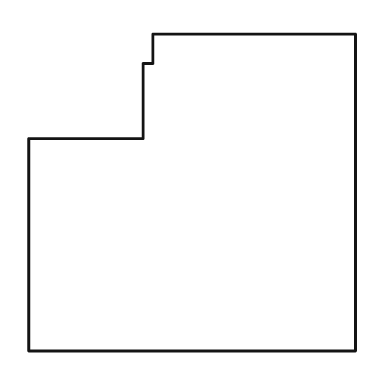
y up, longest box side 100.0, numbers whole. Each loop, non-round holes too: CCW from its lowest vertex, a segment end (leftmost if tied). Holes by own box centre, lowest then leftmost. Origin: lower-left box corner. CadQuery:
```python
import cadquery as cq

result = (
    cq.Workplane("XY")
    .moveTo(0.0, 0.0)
    .lineTo(100.0, 0.0)
    .lineTo(100.0, 97.0)
    .lineTo(38.0, 97.0)
    .lineTo(38.0, 88.0)
    .lineTo(35.0, 88.0)
    .lineTo(35.0, 65.0)
    .lineTo(0.0, 65.0)
    .close()
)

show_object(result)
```